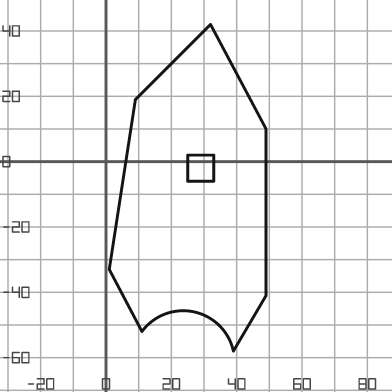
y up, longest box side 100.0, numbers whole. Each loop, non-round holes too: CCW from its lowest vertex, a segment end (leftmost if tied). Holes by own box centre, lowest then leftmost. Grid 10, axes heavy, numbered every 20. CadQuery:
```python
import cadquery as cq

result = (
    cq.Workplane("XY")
    .moveTo(39.0, -58.0)
    .lineTo(49.0, -41.0)
    .lineTo(49.0, 10.0)
    .lineTo(32.0, 42.0)
    .lineTo(9.0, 19.0)
    .lineTo(1.0, -33.0)
    .lineTo(11.0, -52.0)
    .threePointArc((27.0, -46.0), (39.0, -58.0))
    .close()
    .moveTo(25.0, -6.0)
    .lineTo(33.0, -6.0)
    .lineTo(33.0, 2.0)
    .lineTo(25.0, 2.0)
    .close()
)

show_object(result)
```